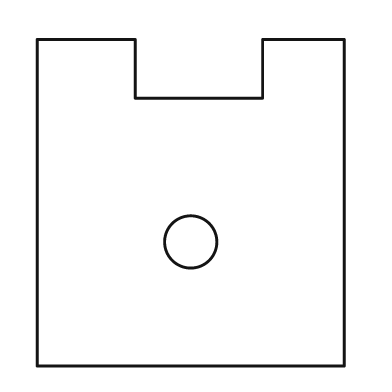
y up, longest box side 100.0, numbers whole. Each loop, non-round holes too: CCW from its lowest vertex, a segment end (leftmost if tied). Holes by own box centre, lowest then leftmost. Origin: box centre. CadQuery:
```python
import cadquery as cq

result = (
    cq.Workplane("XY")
    .moveTo(-47.0, -50.0)
    .lineTo(47.0, -50.0)
    .lineTo(47.0, 50.0)
    .lineTo(22.0, 50.0)
    .lineTo(22.0, 32.0)
    .lineTo(-17.0, 32.0)
    .lineTo(-17.0, 50.0)
    .lineTo(-47.0, 50.0)
    .close()
    .moveTo(0.0, -12.0)
    .circle(8.0)
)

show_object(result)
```